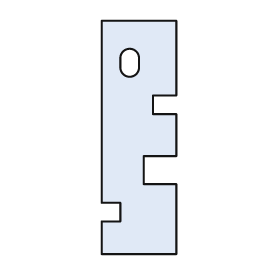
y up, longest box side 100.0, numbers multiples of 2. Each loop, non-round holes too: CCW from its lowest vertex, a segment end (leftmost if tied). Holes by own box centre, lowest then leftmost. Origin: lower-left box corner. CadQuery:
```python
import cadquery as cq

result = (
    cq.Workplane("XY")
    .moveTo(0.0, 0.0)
    .lineTo(32.0, 0.0)
    .lineTo(32.0, 30.0)
    .lineTo(18.0, 30.0)
    .lineTo(18.0, 42.0)
    .lineTo(32.0, 42.0)
    .lineTo(32.0, 60.0)
    .lineTo(22.0, 60.0)
    .lineTo(22.0, 68.0)
    .lineTo(32.0, 68.0)
    .lineTo(32.0, 100.0)
    .lineTo(0.0, 100.0)
    .lineTo(0.0, 22.0)
    .lineTo(8.0, 22.0)
    .lineTo(8.0, 14.0)
    .lineTo(0.0, 14.0)
    .close()
    .moveTo(8.0, 80.0)
    .threePointArc((12.0, 76.0), (16.0, 80.0))
    .lineTo(16.0, 84.0)
    .threePointArc((12.0, 88.0), (8.0, 84.0))
    .close()
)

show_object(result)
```